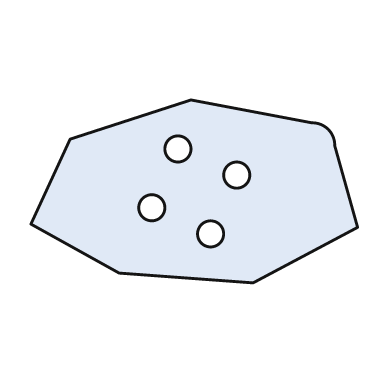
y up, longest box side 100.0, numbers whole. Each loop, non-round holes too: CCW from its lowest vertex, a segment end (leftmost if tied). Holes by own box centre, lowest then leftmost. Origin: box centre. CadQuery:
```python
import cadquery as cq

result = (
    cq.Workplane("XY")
    .moveTo(18.0, -28.0)
    .lineTo(50.0, -11.0)
    .lineTo(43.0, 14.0)
    .threePointArc((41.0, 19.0), (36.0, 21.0))
    .lineTo(-1.0, 28.0)
    .lineTo(-38.0, 16.0)
    .lineTo(-50.0, -10.0)
    .lineTo(-23.0, -25.0)
    .close()
    .moveTo(5.0, -13.0)
    .circle(4.0)
    .moveTo(-13.0, -5.0)
    .circle(4.0)
    .moveTo(13.0, 5.0)
    .circle(4.0)
    .moveTo(-5.0, 13.0)
    .circle(4.0)
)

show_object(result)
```